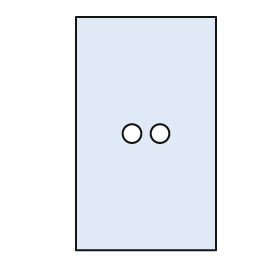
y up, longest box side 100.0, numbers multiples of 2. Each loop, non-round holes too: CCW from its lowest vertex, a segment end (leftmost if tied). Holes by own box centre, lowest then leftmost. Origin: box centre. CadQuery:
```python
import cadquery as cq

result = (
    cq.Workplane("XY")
    .moveTo(-30.0, -50.0)
    .lineTo(30.0, -50.0)
    .lineTo(30.0, 50.0)
    .lineTo(-30.0, 50.0)
    .close()
    .moveTo(-6.0, 0.0)
    .circle(4.0)
    .moveTo(6.0, 0.0)
    .circle(4.0)
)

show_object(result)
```